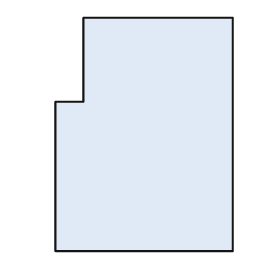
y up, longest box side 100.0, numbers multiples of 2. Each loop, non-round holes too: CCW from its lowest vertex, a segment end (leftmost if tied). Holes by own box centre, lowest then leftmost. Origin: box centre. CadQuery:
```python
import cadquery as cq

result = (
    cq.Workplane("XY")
    .moveTo(-38.0, -50.0)
    .lineTo(38.0, -50.0)
    .lineTo(38.0, 50.0)
    .lineTo(-26.0, 50.0)
    .lineTo(-26.0, 14.0)
    .lineTo(-38.0, 14.0)
    .close()
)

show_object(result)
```